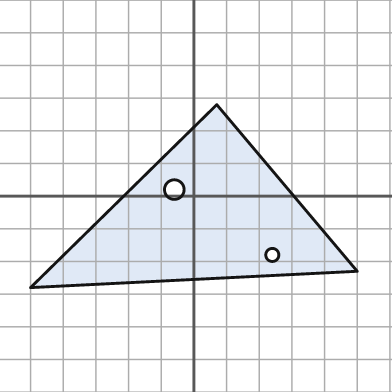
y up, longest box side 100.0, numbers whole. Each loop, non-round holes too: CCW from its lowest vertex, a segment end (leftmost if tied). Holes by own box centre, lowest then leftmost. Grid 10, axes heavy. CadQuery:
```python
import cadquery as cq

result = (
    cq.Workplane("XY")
    .moveTo(-50.0, -28.0)
    .lineTo(50.0, -23.0)
    .lineTo(7.0, 28.0)
    .close()
    .moveTo(24.0, -18.0)
    .circle(2.0)
    .moveTo(-6.0, 2.0)
    .circle(3.0)
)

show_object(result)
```